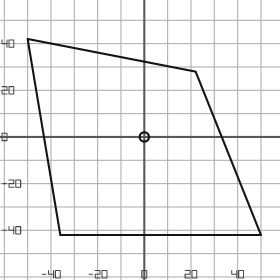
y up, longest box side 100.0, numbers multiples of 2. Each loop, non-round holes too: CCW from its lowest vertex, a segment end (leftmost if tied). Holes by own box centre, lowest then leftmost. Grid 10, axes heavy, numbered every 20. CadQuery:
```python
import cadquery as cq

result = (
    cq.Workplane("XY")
    .moveTo(-36.0, -42.0)
    .lineTo(50.0, -42.0)
    .lineTo(22.0, 28.0)
    .lineTo(-50.0, 42.0)
    .close()
    .moveTo(0.0, 0.0)
    .circle(2.0)
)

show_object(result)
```